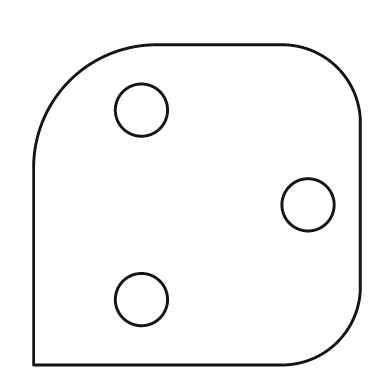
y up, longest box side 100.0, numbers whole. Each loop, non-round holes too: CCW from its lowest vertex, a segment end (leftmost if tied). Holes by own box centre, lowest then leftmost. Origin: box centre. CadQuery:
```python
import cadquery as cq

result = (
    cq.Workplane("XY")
    .moveTo(-50.0, -49.0)
    .lineTo(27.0, -49.0)
    .threePointArc((43.0, -42.0), (50.0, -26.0))
    .lineTo(50.0, 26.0)
    .threePointArc((43.0, 42.0), (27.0, 49.0))
    .lineTo(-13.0, 49.0)
    .threePointArc((-39.0, 38.0), (-50.0, 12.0))
    .close()
    .moveTo(-17.0, -29.0)
    .circle(8.0)
    .moveTo(34.0, 0.0)
    .circle(8.0)
    .moveTo(-17.0, 29.0)
    .circle(8.0)
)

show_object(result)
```